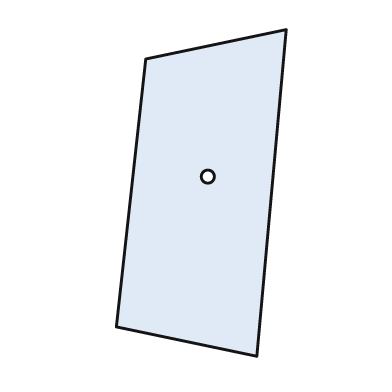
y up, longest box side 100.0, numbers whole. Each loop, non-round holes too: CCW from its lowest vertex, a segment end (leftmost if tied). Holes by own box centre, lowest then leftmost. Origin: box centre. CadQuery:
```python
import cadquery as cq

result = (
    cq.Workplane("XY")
    .moveTo(17.0, -50.0)
    .lineTo(26.0, 50.0)
    .lineTo(-17.0, 41.0)
    .lineTo(-26.0, -41.0)
    .close()
    .moveTo(2.0, 5.0)
    .circle(2.0)
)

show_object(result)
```